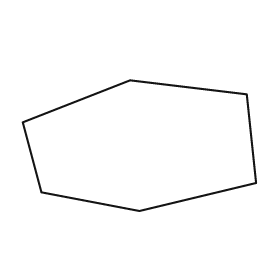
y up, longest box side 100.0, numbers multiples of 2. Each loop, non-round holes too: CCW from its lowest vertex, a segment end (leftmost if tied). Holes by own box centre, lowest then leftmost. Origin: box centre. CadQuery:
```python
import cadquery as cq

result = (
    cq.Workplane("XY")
    .moveTo(0.0, -28.0)
    .lineTo(50.0, -16.0)
    .lineTo(46.0, 22.0)
    .lineTo(-4.0, 28.0)
    .lineTo(-50.0, 10.0)
    .lineTo(-42.0, -20.0)
    .close()
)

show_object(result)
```